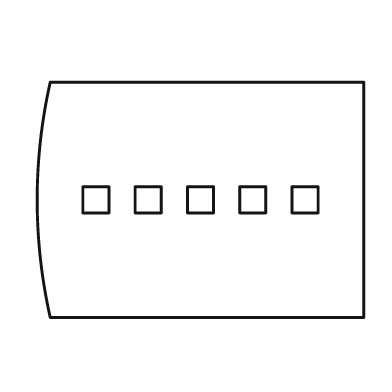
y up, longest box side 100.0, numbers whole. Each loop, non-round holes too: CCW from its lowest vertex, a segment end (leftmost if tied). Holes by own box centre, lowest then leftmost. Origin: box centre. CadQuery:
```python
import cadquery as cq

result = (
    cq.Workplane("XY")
    .moveTo(-46.0, -36.0)
    .lineTo(50.0, -36.0)
    .lineTo(50.0, 36.0)
    .lineTo(-46.0, 36.0)
    .threePointArc((-50.0, 0.0), (-46.0, -36.0))
    .close()
    .moveTo(-36.0, -4.0)
    .lineTo(-28.0, -4.0)
    .lineTo(-28.0, 4.0)
    .lineTo(-36.0, 4.0)
    .close()
    .moveTo(-20.0, -4.0)
    .lineTo(-12.0, -4.0)
    .lineTo(-12.0, 4.0)
    .lineTo(-20.0, 4.0)
    .close()
    .moveTo(-4.0, -4.0)
    .lineTo(4.0, -4.0)
    .lineTo(4.0, 4.0)
    .lineTo(-4.0, 4.0)
    .close()
    .moveTo(12.0, -4.0)
    .lineTo(20.0, -4.0)
    .lineTo(20.0, 4.0)
    .lineTo(12.0, 4.0)
    .close()
    .moveTo(28.0, -4.0)
    .lineTo(36.0, -4.0)
    .lineTo(36.0, 4.0)
    .lineTo(28.0, 4.0)
    .close()
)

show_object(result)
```